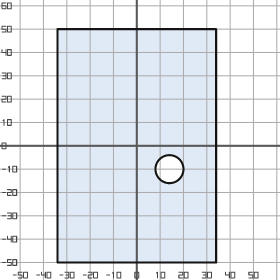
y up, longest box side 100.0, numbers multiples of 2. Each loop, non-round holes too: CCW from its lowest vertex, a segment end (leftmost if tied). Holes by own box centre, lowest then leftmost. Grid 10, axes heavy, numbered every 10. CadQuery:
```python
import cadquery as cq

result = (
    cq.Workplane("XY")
    .moveTo(-34.0, -50.0)
    .lineTo(34.0, -50.0)
    .lineTo(34.0, 50.0)
    .lineTo(-34.0, 50.0)
    .close()
    .moveTo(14.0, -10.0)
    .circle(6.0)
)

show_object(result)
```